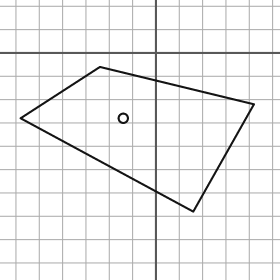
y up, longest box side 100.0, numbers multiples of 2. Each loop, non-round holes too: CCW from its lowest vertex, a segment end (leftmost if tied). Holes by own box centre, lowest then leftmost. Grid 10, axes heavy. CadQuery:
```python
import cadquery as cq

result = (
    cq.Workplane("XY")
    .moveTo(16.0, -68.0)
    .lineTo(42.0, -22.0)
    .lineTo(-24.0, -6.0)
    .lineTo(-58.0, -28.0)
    .close()
    .moveTo(-14.0, -28.0)
    .circle(2.0)
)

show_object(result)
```